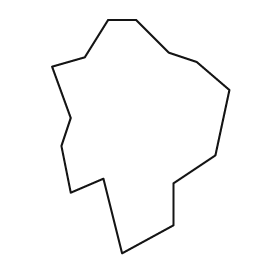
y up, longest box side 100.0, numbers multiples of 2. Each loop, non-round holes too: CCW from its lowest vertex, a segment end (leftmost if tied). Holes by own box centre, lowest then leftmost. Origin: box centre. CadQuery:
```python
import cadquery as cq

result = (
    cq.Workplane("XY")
    .moveTo(-8.0, -50.0)
    .lineTo(14.0, -38.0)
    .lineTo(14.0, -20.0)
    .lineTo(32.0, -8.0)
    .lineTo(38.0, 20.0)
    .lineTo(24.0, 32.0)
    .lineTo(12.0, 36.0)
    .lineTo(-2.0, 50.0)
    .lineTo(-14.0, 50.0)
    .lineTo(-24.0, 34.0)
    .lineTo(-38.0, 30.0)
    .lineTo(-30.0, 8.0)
    .lineTo(-34.0, -4.0)
    .lineTo(-30.0, -24.0)
    .lineTo(-16.0, -18.0)
    .close()
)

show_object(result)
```